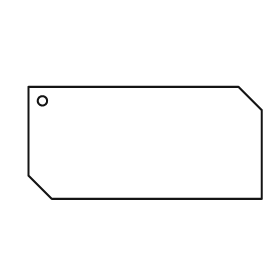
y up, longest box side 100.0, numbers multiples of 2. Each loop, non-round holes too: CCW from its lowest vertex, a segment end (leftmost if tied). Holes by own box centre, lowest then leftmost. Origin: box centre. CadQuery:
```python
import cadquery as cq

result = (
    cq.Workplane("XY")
    .moveTo(-40.0, -24.0)
    .lineTo(50.0, -24.0)
    .lineTo(50.0, 14.0)
    .lineTo(40.0, 24.0)
    .lineTo(-50.0, 24.0)
    .lineTo(-50.0, -14.0)
    .close()
    .moveTo(-44.0, 18.0)
    .circle(2.0)
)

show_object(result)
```